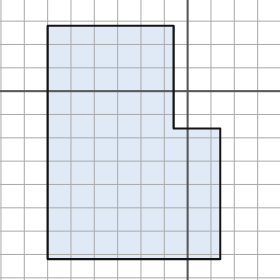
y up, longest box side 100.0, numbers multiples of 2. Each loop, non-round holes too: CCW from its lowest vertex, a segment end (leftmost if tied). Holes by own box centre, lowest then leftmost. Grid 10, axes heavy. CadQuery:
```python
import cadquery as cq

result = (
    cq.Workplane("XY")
    .moveTo(-60.0, -72.0)
    .lineTo(14.0, -72.0)
    .lineTo(14.0, -16.0)
    .lineTo(-6.0, -16.0)
    .lineTo(-6.0, 28.0)
    .lineTo(-60.0, 28.0)
    .close()
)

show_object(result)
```